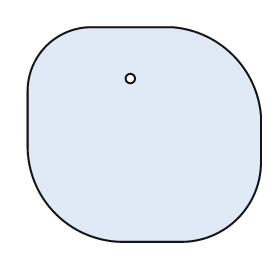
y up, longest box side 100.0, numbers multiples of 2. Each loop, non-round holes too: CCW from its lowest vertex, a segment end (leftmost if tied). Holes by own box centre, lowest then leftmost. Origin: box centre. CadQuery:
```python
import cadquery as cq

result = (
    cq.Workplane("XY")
    .moveTo(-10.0, -46.0)
    .lineTo(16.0, -46.0)
    .threePointArc((40.0, -36.0), (50.0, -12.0))
    .lineTo(50.0, 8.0)
    .threePointArc((38.0, 34.0), (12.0, 46.0))
    .lineTo(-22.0, 46.0)
    .threePointArc((-42.0, 38.0), (-50.0, 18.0))
    .lineTo(-50.0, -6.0)
    .threePointArc((-38.0, -34.0), (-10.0, -46.0))
    .close()
    .moveTo(-6.0, 24.0)
    .circle(2.0)
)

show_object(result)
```